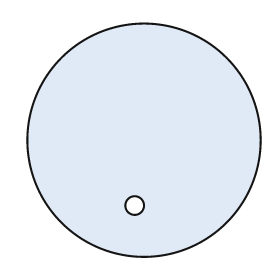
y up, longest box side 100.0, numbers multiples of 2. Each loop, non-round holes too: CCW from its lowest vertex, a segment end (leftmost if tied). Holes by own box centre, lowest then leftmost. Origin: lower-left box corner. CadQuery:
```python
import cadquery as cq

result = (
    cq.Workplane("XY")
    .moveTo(50.0, 50.0)
    .circle(50.0)
    .moveTo(46.0, 22.0)
    .circle(4.0)
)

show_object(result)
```